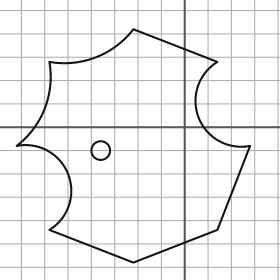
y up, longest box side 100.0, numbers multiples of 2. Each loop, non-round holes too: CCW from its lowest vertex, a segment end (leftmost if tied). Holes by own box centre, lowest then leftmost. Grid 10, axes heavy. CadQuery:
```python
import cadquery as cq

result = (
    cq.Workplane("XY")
    .moveTo(-22.0, -58.0)
    .lineTo(14.0, -44.0)
    .lineTo(28.0, -8.0)
    .threePointArc((6.0, 4.0), (14.0, 28.0))
    .lineTo(-22.0, 42.0)
    .threePointArc((-38.0, 30.0), (-58.0, 28.0))
    .threePointArc((-60.0, 8.0), (-72.0, -8.0))
    .threePointArc((-50.0, -20.0), (-58.0, -44.0))
    .close()
    .moveTo(-36.0, -10.0)
    .circle(4.0)
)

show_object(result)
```